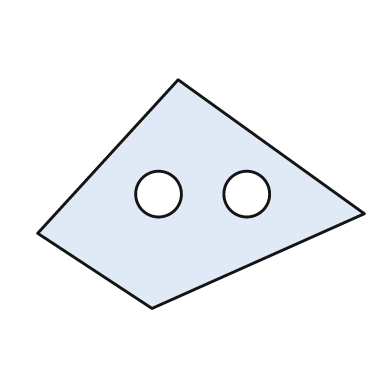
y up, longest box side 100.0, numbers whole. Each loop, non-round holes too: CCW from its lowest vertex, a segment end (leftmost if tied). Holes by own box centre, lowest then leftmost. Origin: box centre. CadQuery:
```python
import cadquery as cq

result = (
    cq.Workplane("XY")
    .moveTo(-15.0, -35.0)
    .lineTo(50.0, -6.0)
    .lineTo(-7.0, 35.0)
    .lineTo(-50.0, -12.0)
    .close()
    .moveTo(-13.0, 0.0)
    .circle(7.0)
    .moveTo(14.0, 0.0)
    .circle(7.0)
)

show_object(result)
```